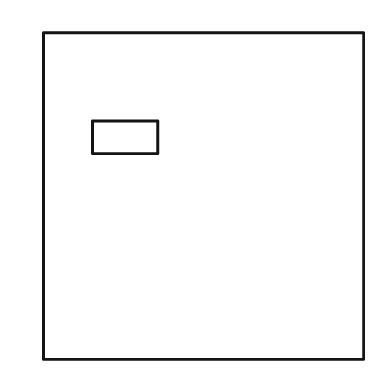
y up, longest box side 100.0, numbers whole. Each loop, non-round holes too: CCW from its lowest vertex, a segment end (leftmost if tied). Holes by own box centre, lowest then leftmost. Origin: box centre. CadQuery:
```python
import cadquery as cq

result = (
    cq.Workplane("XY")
    .moveTo(-49.0, -50.0)
    .lineTo(49.0, -50.0)
    .lineTo(49.0, 50.0)
    .lineTo(-49.0, 50.0)
    .close()
    .moveTo(-34.0, 13.0)
    .lineTo(-14.0, 13.0)
    .lineTo(-14.0, 23.0)
    .lineTo(-34.0, 23.0)
    .close()
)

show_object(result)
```